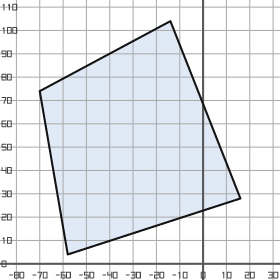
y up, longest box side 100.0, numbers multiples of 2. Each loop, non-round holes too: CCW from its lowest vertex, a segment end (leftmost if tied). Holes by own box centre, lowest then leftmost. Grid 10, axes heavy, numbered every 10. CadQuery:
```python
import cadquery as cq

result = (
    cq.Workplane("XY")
    .moveTo(-58.0, 4.0)
    .lineTo(16.0, 28.0)
    .lineTo(-14.0, 104.0)
    .lineTo(-70.0, 74.0)
    .close()
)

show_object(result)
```